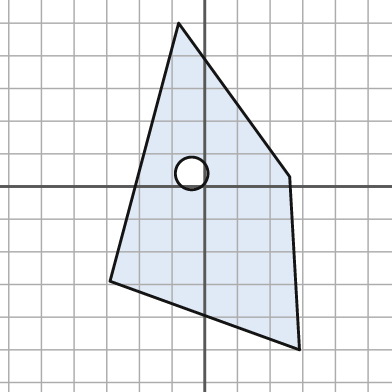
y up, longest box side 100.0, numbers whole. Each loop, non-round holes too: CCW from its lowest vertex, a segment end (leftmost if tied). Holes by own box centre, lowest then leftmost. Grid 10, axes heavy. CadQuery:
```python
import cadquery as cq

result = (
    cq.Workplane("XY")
    .moveTo(29.0, -50.0)
    .lineTo(26.0, 3.0)
    .lineTo(-8.0, 50.0)
    .lineTo(-29.0, -29.0)
    .close()
    .moveTo(-4.0, 4.0)
    .circle(5.0)
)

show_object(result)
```